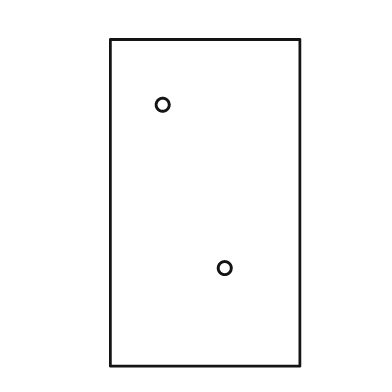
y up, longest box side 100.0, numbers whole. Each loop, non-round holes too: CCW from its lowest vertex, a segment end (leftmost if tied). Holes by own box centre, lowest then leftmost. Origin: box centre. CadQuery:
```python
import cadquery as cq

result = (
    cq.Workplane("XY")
    .moveTo(-29.0, -50.0)
    .lineTo(29.0, -50.0)
    .lineTo(29.0, 50.0)
    .lineTo(-29.0, 50.0)
    .close()
    .moveTo(6.0, -20.0)
    .circle(2.0)
    .moveTo(-13.0, 30.0)
    .circle(2.0)
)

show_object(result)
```